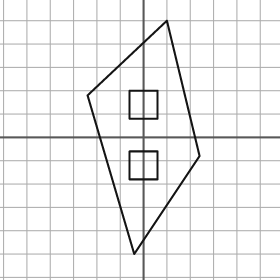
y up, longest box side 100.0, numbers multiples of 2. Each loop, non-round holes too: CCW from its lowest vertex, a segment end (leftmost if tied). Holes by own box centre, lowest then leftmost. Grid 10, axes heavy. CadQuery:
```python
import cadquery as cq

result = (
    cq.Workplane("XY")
    .moveTo(-4.0, -50.0)
    .lineTo(24.0, -8.0)
    .lineTo(10.0, 50.0)
    .lineTo(-24.0, 18.0)
    .close()
    .moveTo(-6.0, -18.0)
    .lineTo(6.0, -18.0)
    .lineTo(6.0, -6.0)
    .lineTo(-6.0, -6.0)
    .close()
    .moveTo(-6.0, 8.0)
    .lineTo(6.0, 8.0)
    .lineTo(6.0, 20.0)
    .lineTo(-6.0, 20.0)
    .close()
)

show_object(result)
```